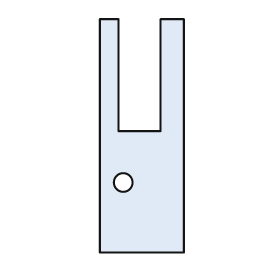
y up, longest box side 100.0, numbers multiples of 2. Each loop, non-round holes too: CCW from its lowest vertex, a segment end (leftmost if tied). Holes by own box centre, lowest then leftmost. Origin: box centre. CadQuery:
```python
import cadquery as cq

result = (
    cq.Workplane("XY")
    .moveTo(-18.0, -50.0)
    .lineTo(18.0, -50.0)
    .lineTo(18.0, 50.0)
    .lineTo(8.0, 50.0)
    .lineTo(8.0, 2.0)
    .lineTo(-10.0, 2.0)
    .lineTo(-10.0, 50.0)
    .lineTo(-18.0, 50.0)
    .close()
    .moveTo(-8.0, -20.0)
    .circle(4.0)
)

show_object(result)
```